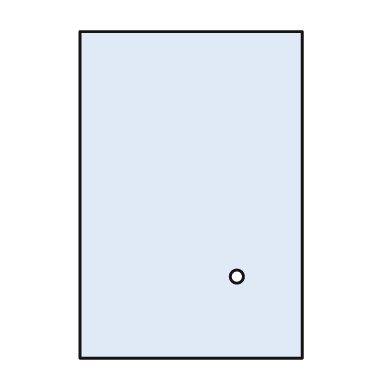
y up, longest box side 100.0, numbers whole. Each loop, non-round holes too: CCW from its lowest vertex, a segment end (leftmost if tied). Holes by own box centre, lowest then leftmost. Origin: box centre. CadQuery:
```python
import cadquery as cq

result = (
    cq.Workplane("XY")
    .moveTo(-34.0, -50.0)
    .lineTo(34.0, -50.0)
    .lineTo(34.0, 50.0)
    .lineTo(-34.0, 50.0)
    .close()
    .moveTo(14.0, -25.0)
    .circle(2.0)
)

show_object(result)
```